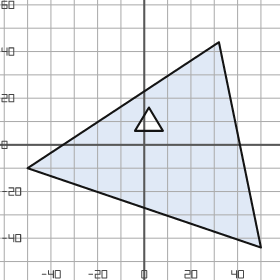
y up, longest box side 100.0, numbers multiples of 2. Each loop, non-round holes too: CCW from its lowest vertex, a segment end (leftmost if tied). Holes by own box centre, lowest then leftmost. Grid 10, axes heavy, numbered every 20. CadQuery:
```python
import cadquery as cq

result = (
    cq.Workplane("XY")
    .moveTo(50.0, -44.0)
    .lineTo(32.0, 44.0)
    .lineTo(-50.0, -10.0)
    .close()
    .moveTo(-4.0, 6.0)
    .lineTo(8.0, 6.0)
    .lineTo(2.0, 16.0)
    .close()
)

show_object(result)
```